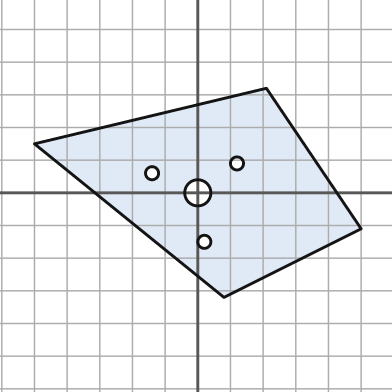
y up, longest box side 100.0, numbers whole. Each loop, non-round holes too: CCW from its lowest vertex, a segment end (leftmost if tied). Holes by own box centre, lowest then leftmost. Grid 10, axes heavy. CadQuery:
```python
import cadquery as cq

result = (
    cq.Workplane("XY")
    .moveTo(8.0, -32.0)
    .lineTo(50.0, -11.0)
    .lineTo(21.0, 32.0)
    .lineTo(-50.0, 15.0)
    .close()
    .moveTo(2.0, -15.0)
    .circle(2.0)
    .moveTo(0.0, 0.0)
    .circle(4.0)
    .moveTo(-14.0, 6.0)
    .circle(2.0)
    .moveTo(12.0, 9.0)
    .circle(2.0)
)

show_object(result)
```